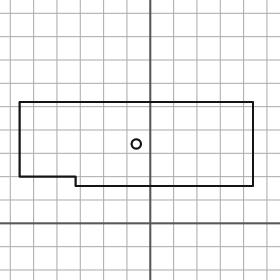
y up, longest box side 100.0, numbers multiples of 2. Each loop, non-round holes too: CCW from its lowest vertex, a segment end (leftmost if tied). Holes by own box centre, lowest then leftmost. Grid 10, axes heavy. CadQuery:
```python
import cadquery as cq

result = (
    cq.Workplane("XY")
    .moveTo(-32.0, 16.0)
    .lineTo(44.0, 16.0)
    .lineTo(44.0, 52.0)
    .lineTo(-56.0, 52.0)
    .lineTo(-56.0, 20.0)
    .lineTo(-32.0, 20.0)
    .close()
    .moveTo(-6.0, 34.0)
    .circle(2.0)
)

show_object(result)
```